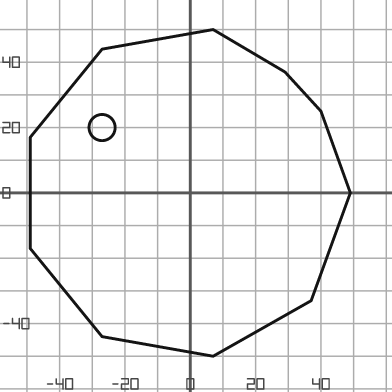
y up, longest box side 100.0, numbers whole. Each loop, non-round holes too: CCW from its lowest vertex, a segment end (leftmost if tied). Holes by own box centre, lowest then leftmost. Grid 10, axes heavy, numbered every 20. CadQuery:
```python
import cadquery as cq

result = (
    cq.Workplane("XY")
    .moveTo(7.0, -50.0)
    .lineTo(37.0, -33.0)
    .lineTo(49.0, 0.0)
    .lineTo(40.0, 25.0)
    .lineTo(29.0, 37.0)
    .lineTo(7.0, 50.0)
    .lineTo(-27.0, 44.0)
    .lineTo(-49.0, 17.0)
    .lineTo(-49.0, -17.0)
    .lineTo(-27.0, -44.0)
    .close()
    .moveTo(-27.0, 20.0)
    .circle(4.0)
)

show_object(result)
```